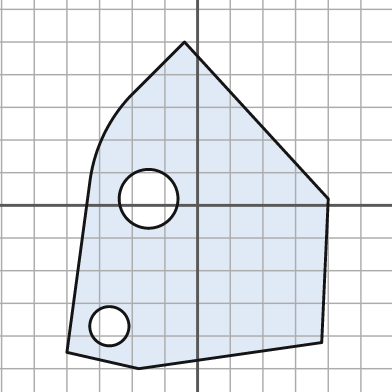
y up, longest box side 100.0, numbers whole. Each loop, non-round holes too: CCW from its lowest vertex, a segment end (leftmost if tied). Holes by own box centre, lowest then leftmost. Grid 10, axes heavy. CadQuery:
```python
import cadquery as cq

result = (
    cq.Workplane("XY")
    .moveTo(-18.0, -50.0)
    .lineTo(38.0, -42.0)
    .lineTo(40.0, 2.0)
    .lineTo(-4.0, 50.0)
    .lineTo(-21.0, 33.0)
    .threePointArc((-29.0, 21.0), (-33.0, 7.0))
    .lineTo(-40.0, -45.0)
    .close()
    .moveTo(-27.0, -37.0)
    .circle(6.0)
    .moveTo(-15.0, 2.0)
    .circle(9.0)
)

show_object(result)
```